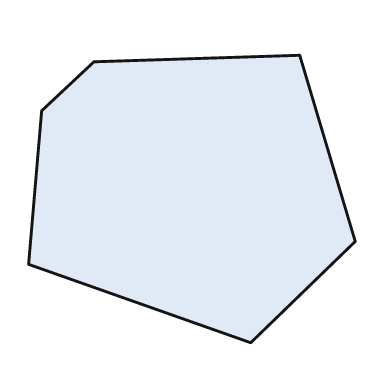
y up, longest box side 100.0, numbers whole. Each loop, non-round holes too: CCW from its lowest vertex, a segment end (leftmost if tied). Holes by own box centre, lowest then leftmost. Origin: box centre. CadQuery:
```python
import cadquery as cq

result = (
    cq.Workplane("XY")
    .moveTo(18.0, -44.0)
    .lineTo(50.0, -13.0)
    .lineTo(33.0, 44.0)
    .lineTo(-30.0, 42.0)
    .lineTo(-46.0, 27.0)
    .lineTo(-50.0, -20.0)
    .close()
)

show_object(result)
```